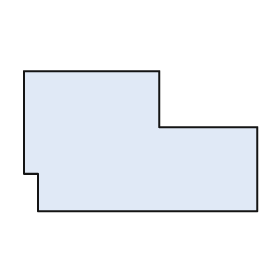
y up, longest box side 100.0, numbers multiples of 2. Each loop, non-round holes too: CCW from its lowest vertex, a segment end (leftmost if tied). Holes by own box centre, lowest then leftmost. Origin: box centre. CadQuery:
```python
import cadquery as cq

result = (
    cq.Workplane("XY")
    .moveTo(-44.0, -30.0)
    .lineTo(50.0, -30.0)
    .lineTo(50.0, 6.0)
    .lineTo(8.0, 6.0)
    .lineTo(8.0, 30.0)
    .lineTo(-50.0, 30.0)
    .lineTo(-50.0, -14.0)
    .lineTo(-44.0, -14.0)
    .close()
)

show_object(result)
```